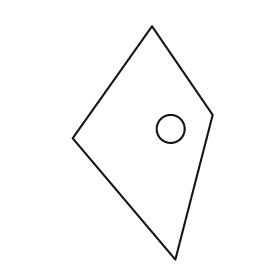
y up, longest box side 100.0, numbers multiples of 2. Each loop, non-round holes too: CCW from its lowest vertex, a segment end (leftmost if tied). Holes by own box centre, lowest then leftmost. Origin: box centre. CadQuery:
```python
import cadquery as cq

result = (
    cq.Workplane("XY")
    .moveTo(14.0, -50.0)
    .lineTo(30.0, 12.0)
    .lineTo(4.0, 50.0)
    .lineTo(-30.0, 2.0)
    .close()
    .moveTo(12.0, 6.0)
    .circle(6.0)
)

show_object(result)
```